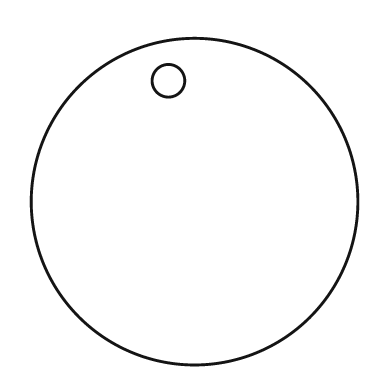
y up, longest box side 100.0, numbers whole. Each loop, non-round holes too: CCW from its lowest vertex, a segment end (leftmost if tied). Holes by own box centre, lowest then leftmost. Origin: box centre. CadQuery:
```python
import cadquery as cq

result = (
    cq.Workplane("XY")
    .moveTo(0.0, 0.0)
    .circle(50.0)
    .moveTo(-8.0, 37.0)
    .circle(5.0)
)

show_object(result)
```